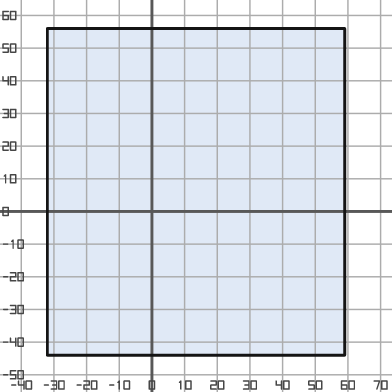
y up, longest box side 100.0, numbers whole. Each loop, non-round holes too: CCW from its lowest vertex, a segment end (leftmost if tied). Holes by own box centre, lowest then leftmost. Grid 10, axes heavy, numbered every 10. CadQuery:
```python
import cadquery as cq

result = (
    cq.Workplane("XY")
    .moveTo(-32.0, -44.0)
    .lineTo(59.0, -44.0)
    .lineTo(59.0, 56.0)
    .lineTo(-32.0, 56.0)
    .close()
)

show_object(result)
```